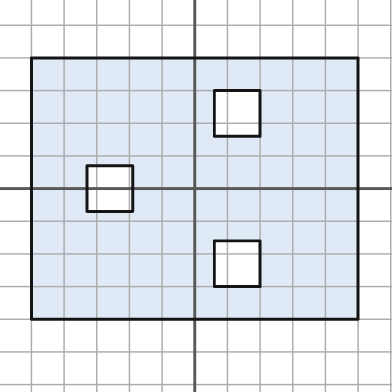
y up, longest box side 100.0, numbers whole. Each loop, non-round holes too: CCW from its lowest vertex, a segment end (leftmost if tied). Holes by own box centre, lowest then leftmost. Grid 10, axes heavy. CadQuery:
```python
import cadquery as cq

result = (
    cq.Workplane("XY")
    .moveTo(-50.0, -40.0)
    .lineTo(50.0, -40.0)
    .lineTo(50.0, 40.0)
    .lineTo(-50.0, 40.0)
    .close()
    .moveTo(6.0, -30.0)
    .lineTo(20.0, -30.0)
    .lineTo(20.0, -16.0)
    .lineTo(6.0, -16.0)
    .close()
    .moveTo(-33.0, -7.0)
    .lineTo(-19.0, -7.0)
    .lineTo(-19.0, 7.0)
    .lineTo(-33.0, 7.0)
    .close()
    .moveTo(6.0, 16.0)
    .lineTo(20.0, 16.0)
    .lineTo(20.0, 30.0)
    .lineTo(6.0, 30.0)
    .close()
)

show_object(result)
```